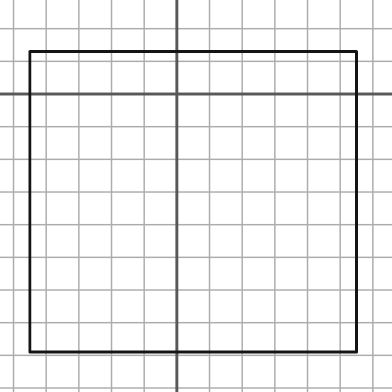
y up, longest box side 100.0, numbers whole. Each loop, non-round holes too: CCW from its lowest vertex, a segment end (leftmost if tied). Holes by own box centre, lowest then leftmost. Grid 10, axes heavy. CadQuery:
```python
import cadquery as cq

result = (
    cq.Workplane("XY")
    .moveTo(-45.0, -79.0)
    .lineTo(55.0, -79.0)
    .lineTo(55.0, 13.0)
    .lineTo(-45.0, 13.0)
    .close()
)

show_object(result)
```